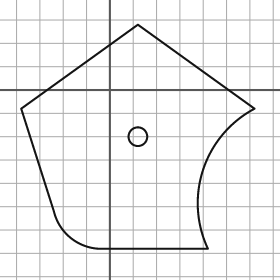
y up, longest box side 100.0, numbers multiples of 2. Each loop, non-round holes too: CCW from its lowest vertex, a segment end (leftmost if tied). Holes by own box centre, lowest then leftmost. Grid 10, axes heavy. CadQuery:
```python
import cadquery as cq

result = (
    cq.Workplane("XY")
    .moveTo(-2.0, -68.0)
    .lineTo(42.0, -68.0)
    .threePointArc((40.0, -34.0), (62.0, -8.0))
    .lineTo(12.0, 28.0)
    .lineTo(-38.0, -8.0)
    .lineTo(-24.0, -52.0)
    .threePointArc((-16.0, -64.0), (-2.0, -68.0))
    .close()
    .moveTo(12.0, -20.0)
    .circle(4.0)
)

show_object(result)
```